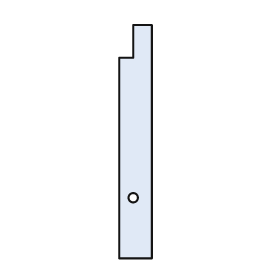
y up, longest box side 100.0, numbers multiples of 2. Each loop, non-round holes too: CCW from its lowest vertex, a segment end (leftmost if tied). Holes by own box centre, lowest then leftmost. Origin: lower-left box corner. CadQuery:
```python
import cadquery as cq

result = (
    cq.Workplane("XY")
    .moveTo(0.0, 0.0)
    .lineTo(14.0, 0.0)
    .lineTo(14.0, 100.0)
    .lineTo(6.0, 100.0)
    .lineTo(6.0, 86.0)
    .lineTo(0.0, 86.0)
    .close()
    .moveTo(6.0, 26.0)
    .circle(2.0)
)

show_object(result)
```